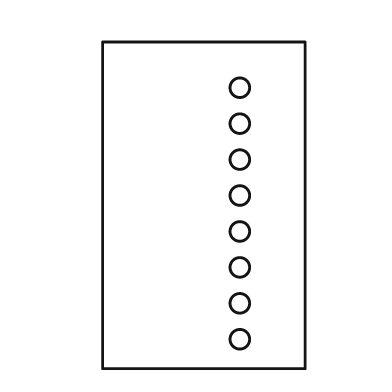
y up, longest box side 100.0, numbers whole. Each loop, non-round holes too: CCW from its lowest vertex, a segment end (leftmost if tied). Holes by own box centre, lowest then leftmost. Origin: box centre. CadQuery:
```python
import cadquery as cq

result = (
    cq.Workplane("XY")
    .moveTo(-31.0, -50.0)
    .lineTo(31.0, -50.0)
    .lineTo(31.0, 50.0)
    .lineTo(-31.0, 50.0)
    .close()
    .moveTo(11.0, -41.0)
    .circle(3.0)
    .moveTo(11.0, -30.0)
    .circle(3.0)
    .moveTo(11.0, -19.0)
    .circle(3.0)
    .moveTo(11.0, -8.0)
    .circle(3.0)
    .moveTo(11.0, 3.0)
    .circle(3.0)
    .moveTo(11.0, 14.0)
    .circle(3.0)
    .moveTo(11.0, 25.0)
    .circle(3.0)
    .moveTo(11.0, 36.0)
    .circle(3.0)
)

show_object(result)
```